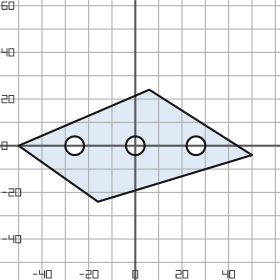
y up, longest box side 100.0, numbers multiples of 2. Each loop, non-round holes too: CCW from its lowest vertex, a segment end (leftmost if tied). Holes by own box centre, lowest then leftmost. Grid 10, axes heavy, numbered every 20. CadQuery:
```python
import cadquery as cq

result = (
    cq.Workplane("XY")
    .moveTo(-16.0, -24.0)
    .lineTo(50.0, -4.0)
    .lineTo(6.0, 24.0)
    .lineTo(-50.0, 0.0)
    .close()
    .moveTo(-26.0, 0.0)
    .circle(4.0)
    .moveTo(0.0, 0.0)
    .circle(4.0)
    .moveTo(26.0, 0.0)
    .circle(4.0)
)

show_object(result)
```